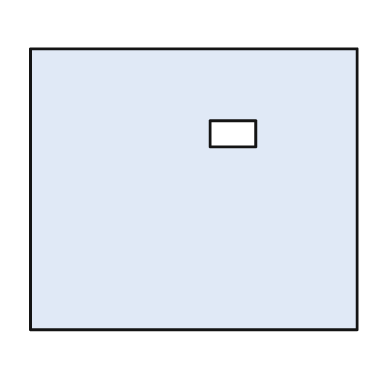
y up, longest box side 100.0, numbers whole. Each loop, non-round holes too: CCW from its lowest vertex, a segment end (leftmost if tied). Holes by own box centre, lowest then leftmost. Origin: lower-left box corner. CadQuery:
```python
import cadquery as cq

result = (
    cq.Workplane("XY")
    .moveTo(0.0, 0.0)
    .lineTo(100.0, 0.0)
    .lineTo(100.0, 86.0)
    .lineTo(0.0, 86.0)
    .close()
    .moveTo(55.0, 56.0)
    .lineTo(69.0, 56.0)
    .lineTo(69.0, 64.0)
    .lineTo(55.0, 64.0)
    .close()
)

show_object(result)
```